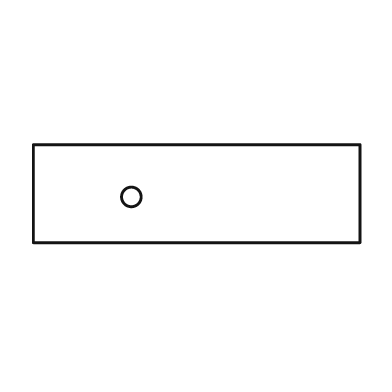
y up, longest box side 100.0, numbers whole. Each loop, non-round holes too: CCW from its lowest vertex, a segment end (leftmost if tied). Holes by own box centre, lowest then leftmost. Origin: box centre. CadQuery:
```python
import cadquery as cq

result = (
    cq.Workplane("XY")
    .moveTo(-50.0, -15.0)
    .lineTo(50.0, -15.0)
    .lineTo(50.0, 15.0)
    .lineTo(-50.0, 15.0)
    .close()
    .moveTo(-20.0, -1.0)
    .circle(3.0)
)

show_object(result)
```